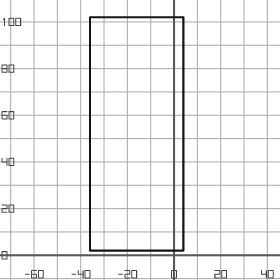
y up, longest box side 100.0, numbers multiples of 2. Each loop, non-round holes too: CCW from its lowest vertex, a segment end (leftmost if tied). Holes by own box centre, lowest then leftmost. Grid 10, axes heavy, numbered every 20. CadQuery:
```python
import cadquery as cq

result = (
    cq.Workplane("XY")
    .moveTo(-36.0, 2.0)
    .lineTo(4.0, 2.0)
    .lineTo(4.0, 102.0)
    .lineTo(-36.0, 102.0)
    .close()
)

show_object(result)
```